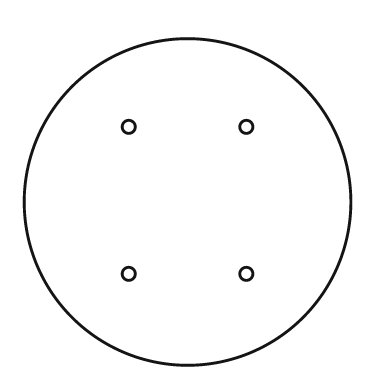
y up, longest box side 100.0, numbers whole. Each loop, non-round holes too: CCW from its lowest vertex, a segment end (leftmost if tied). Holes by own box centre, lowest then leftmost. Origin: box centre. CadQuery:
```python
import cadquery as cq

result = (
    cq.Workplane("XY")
    .moveTo(0.0, 0.0)
    .circle(50.0)
    .moveTo(-18.0, -22.0)
    .circle(2.0)
    .moveTo(18.0, -22.0)
    .circle(2.0)
    .moveTo(-18.0, 23.0)
    .circle(2.0)
    .moveTo(18.0, 23.0)
    .circle(2.0)
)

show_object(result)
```